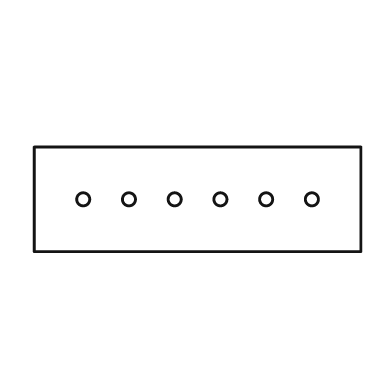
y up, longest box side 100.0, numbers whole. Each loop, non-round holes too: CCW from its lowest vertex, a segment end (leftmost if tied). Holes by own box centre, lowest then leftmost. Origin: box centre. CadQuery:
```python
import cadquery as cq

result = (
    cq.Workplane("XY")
    .moveTo(-50.0, -16.0)
    .lineTo(50.0, -16.0)
    .lineTo(50.0, 16.0)
    .lineTo(-50.0, 16.0)
    .close()
    .moveTo(-35.0, 0.0)
    .circle(2.0)
    .moveTo(-21.0, 0.0)
    .circle(2.0)
    .moveTo(-7.0, 0.0)
    .circle(2.0)
    .moveTo(7.0, 0.0)
    .circle(2.0)
    .moveTo(21.0, 0.0)
    .circle(2.0)
    .moveTo(35.0, 0.0)
    .circle(2.0)
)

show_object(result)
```